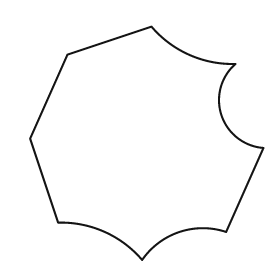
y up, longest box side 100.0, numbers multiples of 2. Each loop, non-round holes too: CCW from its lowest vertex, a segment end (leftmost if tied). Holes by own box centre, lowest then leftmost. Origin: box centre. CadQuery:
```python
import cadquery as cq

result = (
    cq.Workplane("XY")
    .moveTo(-2.0, -50.0)
    .threePointArc((14.0, -38.0), (34.0, -38.0))
    .lineTo(50.0, -2.0)
    .threePointArc((32.0, 12.0), (38.0, 34.0))
    .threePointArc((18.0, 38.0), (2.0, 50.0))
    .lineTo(-34.0, 38.0)
    .lineTo(-50.0, 2.0)
    .lineTo(-38.0, -34.0)
    .threePointArc((-18.0, -38.0), (-2.0, -50.0))
    .close()
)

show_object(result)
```